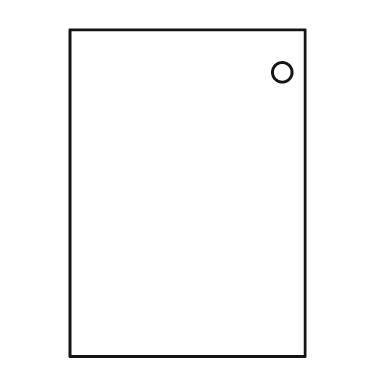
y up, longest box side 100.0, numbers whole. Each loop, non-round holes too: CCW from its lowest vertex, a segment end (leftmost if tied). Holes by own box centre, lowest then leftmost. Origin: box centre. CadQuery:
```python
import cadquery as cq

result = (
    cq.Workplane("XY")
    .moveTo(-36.0, -50.0)
    .lineTo(36.0, -50.0)
    .lineTo(36.0, 50.0)
    .lineTo(-36.0, 50.0)
    .close()
    .moveTo(29.0, 37.0)
    .circle(3.0)
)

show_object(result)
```